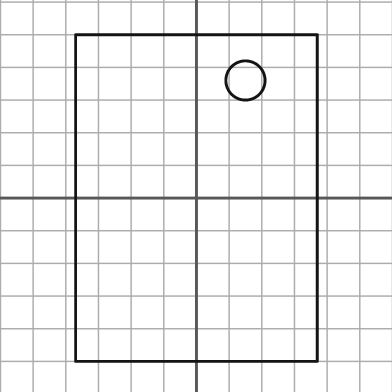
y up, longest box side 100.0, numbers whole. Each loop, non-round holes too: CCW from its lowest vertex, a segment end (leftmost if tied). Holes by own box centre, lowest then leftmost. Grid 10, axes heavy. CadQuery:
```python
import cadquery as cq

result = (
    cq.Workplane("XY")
    .moveTo(-37.0, -50.0)
    .lineTo(37.0, -50.0)
    .lineTo(37.0, 50.0)
    .lineTo(-37.0, 50.0)
    .close()
    .moveTo(15.0, 36.0)
    .circle(6.0)
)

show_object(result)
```